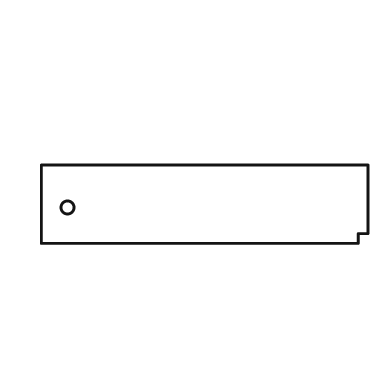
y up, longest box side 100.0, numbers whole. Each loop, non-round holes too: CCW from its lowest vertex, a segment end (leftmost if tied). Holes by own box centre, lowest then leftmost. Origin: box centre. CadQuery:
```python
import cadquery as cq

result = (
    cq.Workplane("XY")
    .moveTo(-50.0, -12.0)
    .lineTo(47.0, -12.0)
    .lineTo(47.0, -9.0)
    .lineTo(50.0, -9.0)
    .lineTo(50.0, 12.0)
    .lineTo(-50.0, 12.0)
    .close()
    .moveTo(-42.0, -1.0)
    .circle(2.0)
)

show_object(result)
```